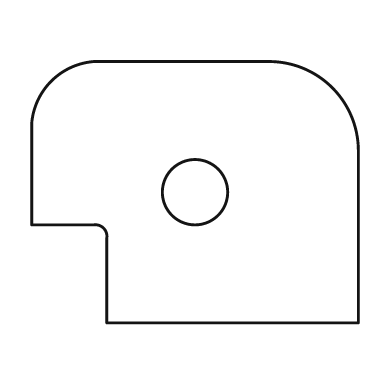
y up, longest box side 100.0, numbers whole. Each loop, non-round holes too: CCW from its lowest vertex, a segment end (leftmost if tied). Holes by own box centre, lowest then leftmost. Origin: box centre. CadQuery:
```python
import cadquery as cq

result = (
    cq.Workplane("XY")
    .moveTo(-27.0, -40.0)
    .lineTo(50.0, -40.0)
    .lineTo(50.0, 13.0)
    .threePointArc((42.0, 32.0), (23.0, 40.0))
    .lineTo(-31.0, 40.0)
    .threePointArc((-44.0, 34.0), (-50.0, 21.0))
    .lineTo(-50.0, -10.0)
    .lineTo(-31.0, -10.0)
    .threePointArc((-28.0, -11.0), (-27.0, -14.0))
    .close()
    .moveTo(0.0, 0.0)
    .circle(10.0)
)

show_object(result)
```